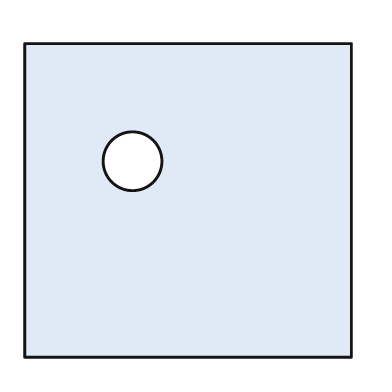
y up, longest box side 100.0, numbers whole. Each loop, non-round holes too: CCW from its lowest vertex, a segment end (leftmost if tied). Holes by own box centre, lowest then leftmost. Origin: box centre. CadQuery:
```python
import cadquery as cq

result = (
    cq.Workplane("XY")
    .moveTo(-50.0, -48.0)
    .lineTo(50.0, -48.0)
    .lineTo(50.0, 48.0)
    .lineTo(-50.0, 48.0)
    .close()
    .moveTo(-17.0, 12.0)
    .circle(9.0)
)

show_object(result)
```